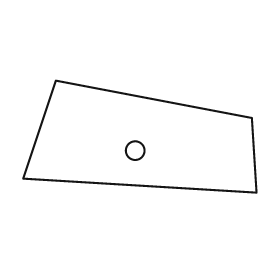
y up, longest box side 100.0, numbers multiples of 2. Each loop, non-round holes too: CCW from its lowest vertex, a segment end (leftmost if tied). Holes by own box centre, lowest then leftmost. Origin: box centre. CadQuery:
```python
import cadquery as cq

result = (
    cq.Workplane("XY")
    .moveTo(50.0, -24.0)
    .lineTo(48.0, 8.0)
    .lineTo(-36.0, 24.0)
    .lineTo(-50.0, -18.0)
    .close()
    .moveTo(-2.0, -6.0)
    .circle(4.0)
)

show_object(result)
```